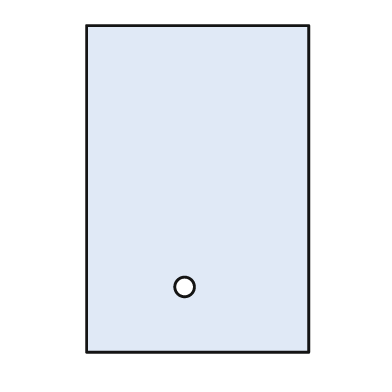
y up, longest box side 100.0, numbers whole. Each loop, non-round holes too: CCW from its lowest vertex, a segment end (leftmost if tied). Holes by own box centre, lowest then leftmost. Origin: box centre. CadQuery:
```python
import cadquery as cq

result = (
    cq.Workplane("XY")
    .moveTo(-34.0, -50.0)
    .lineTo(34.0, -50.0)
    .lineTo(34.0, 50.0)
    .lineTo(-34.0, 50.0)
    .close()
    .moveTo(-4.0, -30.0)
    .circle(3.0)
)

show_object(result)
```